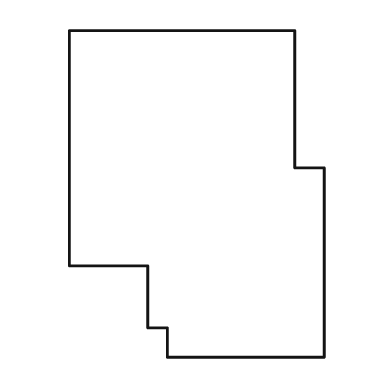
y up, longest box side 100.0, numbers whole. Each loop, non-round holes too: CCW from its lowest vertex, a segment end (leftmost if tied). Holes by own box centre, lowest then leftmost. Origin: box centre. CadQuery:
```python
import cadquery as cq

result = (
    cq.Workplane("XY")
    .moveTo(-9.0, -50.0)
    .lineTo(39.0, -50.0)
    .lineTo(39.0, 8.0)
    .lineTo(30.0, 8.0)
    .lineTo(30.0, 50.0)
    .lineTo(-39.0, 50.0)
    .lineTo(-39.0, -22.0)
    .lineTo(-15.0, -22.0)
    .lineTo(-15.0, -41.0)
    .lineTo(-9.0, -41.0)
    .close()
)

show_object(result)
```